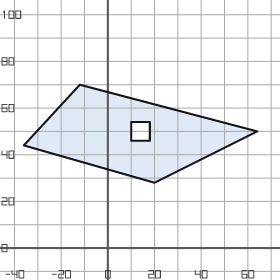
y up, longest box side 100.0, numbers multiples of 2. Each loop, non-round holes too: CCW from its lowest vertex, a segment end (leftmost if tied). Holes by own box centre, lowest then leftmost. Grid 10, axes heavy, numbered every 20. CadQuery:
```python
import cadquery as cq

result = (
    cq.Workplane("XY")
    .moveTo(20.0, 28.0)
    .lineTo(64.0, 50.0)
    .lineTo(-12.0, 70.0)
    .lineTo(-36.0, 44.0)
    .close()
    .moveTo(10.0, 46.0)
    .lineTo(18.0, 46.0)
    .lineTo(18.0, 54.0)
    .lineTo(10.0, 54.0)
    .close()
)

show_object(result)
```